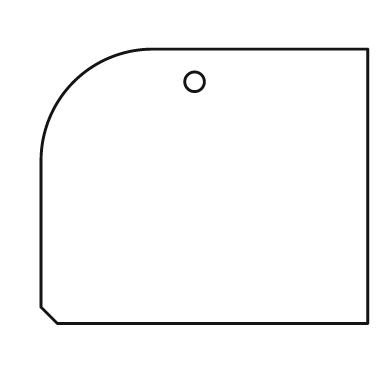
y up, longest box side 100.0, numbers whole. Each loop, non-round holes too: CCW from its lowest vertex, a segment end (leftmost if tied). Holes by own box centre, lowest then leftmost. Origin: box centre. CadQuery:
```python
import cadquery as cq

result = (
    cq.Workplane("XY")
    .moveTo(-45.0, -42.0)
    .lineTo(50.0, -42.0)
    .lineTo(50.0, 42.0)
    .lineTo(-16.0, 42.0)
    .threePointArc((-40.0, 32.0), (-50.0, 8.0))
    .lineTo(-50.0, -37.0)
    .close()
    .moveTo(-3.0, 32.0)
    .circle(3.0)
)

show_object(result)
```